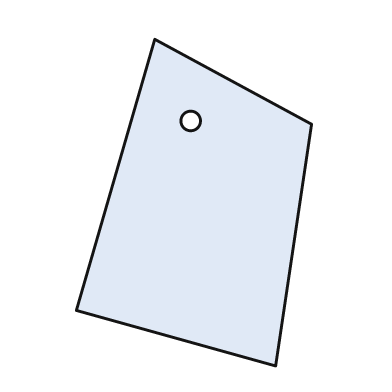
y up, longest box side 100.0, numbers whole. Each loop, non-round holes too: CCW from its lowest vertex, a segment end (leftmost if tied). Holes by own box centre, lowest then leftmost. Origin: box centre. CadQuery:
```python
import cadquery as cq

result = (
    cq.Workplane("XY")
    .moveTo(25.0, -50.0)
    .lineTo(36.0, 24.0)
    .lineTo(-12.0, 50.0)
    .lineTo(-36.0, -33.0)
    .close()
    .moveTo(-1.0, 25.0)
    .circle(3.0)
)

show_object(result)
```